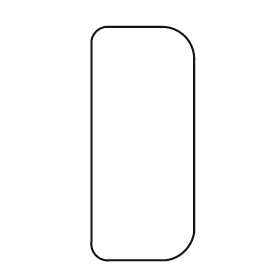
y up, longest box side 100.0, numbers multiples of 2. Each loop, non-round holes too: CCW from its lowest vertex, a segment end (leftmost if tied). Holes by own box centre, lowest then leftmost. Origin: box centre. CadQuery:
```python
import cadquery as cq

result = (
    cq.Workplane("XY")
    .moveTo(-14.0, -50.0)
    .lineTo(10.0, -50.0)
    .threePointArc((18.0, -46.0), (22.0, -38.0))
    .lineTo(22.0, 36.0)
    .threePointArc((18.0, 46.0), (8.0, 50.0))
    .lineTo(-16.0, 50.0)
    .threePointArc((-20.0, 48.0), (-22.0, 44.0))
    .lineTo(-22.0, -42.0)
    .threePointArc((-20.0, -48.0), (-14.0, -50.0))
    .close()
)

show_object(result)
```